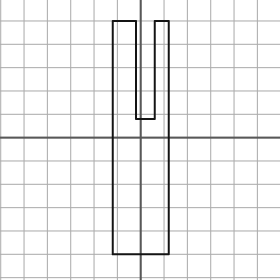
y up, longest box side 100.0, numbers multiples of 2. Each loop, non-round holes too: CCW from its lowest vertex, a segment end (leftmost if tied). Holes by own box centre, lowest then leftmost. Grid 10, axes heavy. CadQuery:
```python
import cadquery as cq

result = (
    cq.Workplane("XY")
    .moveTo(-12.0, -50.0)
    .lineTo(12.0, -50.0)
    .lineTo(12.0, 50.0)
    .lineTo(6.0, 50.0)
    .lineTo(6.0, 8.0)
    .lineTo(-2.0, 8.0)
    .lineTo(-2.0, 50.0)
    .lineTo(-12.0, 50.0)
    .close()
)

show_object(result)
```